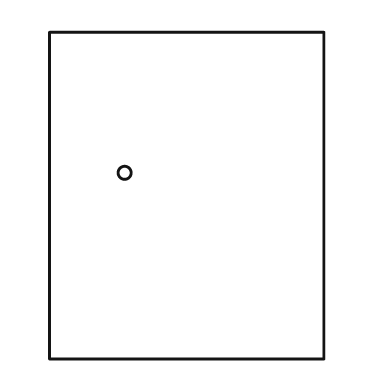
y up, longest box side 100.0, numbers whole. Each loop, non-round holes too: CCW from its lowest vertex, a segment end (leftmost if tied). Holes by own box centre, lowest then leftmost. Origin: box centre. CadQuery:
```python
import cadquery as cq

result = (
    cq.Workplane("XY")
    .moveTo(-42.0, -50.0)
    .lineTo(42.0, -50.0)
    .lineTo(42.0, 50.0)
    .lineTo(-42.0, 50.0)
    .close()
    .moveTo(-19.0, 7.0)
    .circle(2.0)
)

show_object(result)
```